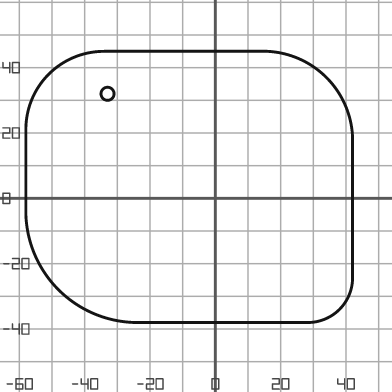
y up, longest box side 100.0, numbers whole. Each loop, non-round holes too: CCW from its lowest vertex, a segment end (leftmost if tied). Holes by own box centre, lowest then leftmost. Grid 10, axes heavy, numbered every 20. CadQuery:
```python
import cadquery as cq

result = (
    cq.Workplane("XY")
    .moveTo(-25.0, -38.0)
    .lineTo(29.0, -38.0)
    .threePointArc((38.0, -34.0), (42.0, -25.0))
    .lineTo(42.0, 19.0)
    .threePointArc((34.0, 37.0), (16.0, 45.0))
    .lineTo(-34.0, 45.0)
    .threePointArc((-51.0, 38.0), (-58.0, 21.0))
    .lineTo(-58.0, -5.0)
    .threePointArc((-48.0, -28.0), (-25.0, -38.0))
    .close()
    .moveTo(-33.0, 32.0)
    .circle(2.0)
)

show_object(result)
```